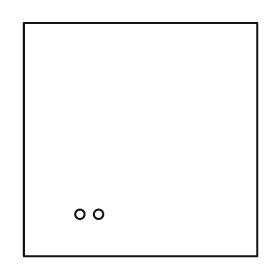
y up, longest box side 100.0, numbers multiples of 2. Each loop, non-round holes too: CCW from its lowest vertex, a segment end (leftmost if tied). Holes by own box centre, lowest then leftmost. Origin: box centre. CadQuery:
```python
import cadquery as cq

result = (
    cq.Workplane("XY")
    .moveTo(-50.0, -50.0)
    .lineTo(50.0, -50.0)
    .lineTo(50.0, 50.0)
    .lineTo(-50.0, 50.0)
    .close()
    .moveTo(-26.0, -32.0)
    .circle(2.0)
    .moveTo(-18.0, -32.0)
    .circle(2.0)
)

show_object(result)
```